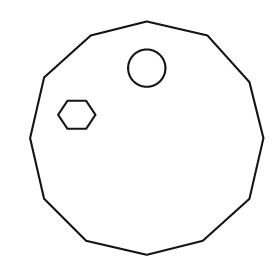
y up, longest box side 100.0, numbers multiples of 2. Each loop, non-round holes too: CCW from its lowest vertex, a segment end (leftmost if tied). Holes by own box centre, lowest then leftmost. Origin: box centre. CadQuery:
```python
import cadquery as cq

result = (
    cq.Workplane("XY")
    .moveTo(0.0, -50.0)
    .lineTo(24.0, -44.0)
    .lineTo(44.0, -26.0)
    .lineTo(50.0, 0.0)
    .lineTo(44.0, 24.0)
    .lineTo(26.0, 44.0)
    .lineTo(0.0, 50.0)
    .lineTo(-24.0, 44.0)
    .lineTo(-44.0, 26.0)
    .lineTo(-50.0, 0.0)
    .lineTo(-44.0, -26.0)
    .lineTo(-26.0, -44.0)
    .close()
    .moveTo(-34.0, 4.0)
    .lineTo(-26.0, 4.0)
    .lineTo(-22.0, 10.0)
    .lineTo(-26.0, 16.0)
    .lineTo(-34.0, 16.0)
    .lineTo(-38.0, 10.0)
    .close()
    .moveTo(0.0, 30.0)
    .circle(8.0)
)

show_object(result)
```